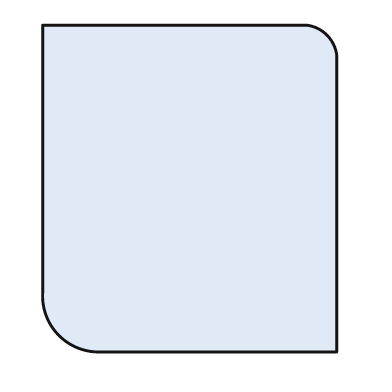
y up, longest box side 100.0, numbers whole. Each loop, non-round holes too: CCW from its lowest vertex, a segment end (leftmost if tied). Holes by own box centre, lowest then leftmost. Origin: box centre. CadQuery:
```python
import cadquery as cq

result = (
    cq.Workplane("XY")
    .moveTo(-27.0, -50.0)
    .lineTo(45.0, -50.0)
    .lineTo(45.0, 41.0)
    .threePointArc((42.0, 47.0), (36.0, 50.0))
    .lineTo(-45.0, 50.0)
    .lineTo(-45.0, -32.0)
    .threePointArc((-40.0, -45.0), (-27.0, -50.0))
    .close()
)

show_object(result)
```